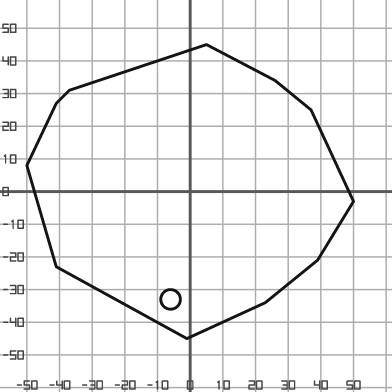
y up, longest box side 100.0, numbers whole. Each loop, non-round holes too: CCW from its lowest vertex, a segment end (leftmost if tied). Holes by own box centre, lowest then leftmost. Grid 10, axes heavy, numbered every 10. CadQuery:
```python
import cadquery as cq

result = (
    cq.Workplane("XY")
    .moveTo(-1.0, -45.0)
    .lineTo(23.0, -34.0)
    .lineTo(39.0, -21.0)
    .lineTo(50.0, -3.0)
    .lineTo(37.0, 25.0)
    .lineTo(26.0, 34.0)
    .lineTo(5.0, 45.0)
    .lineTo(-37.0, 31.0)
    .lineTo(-41.0, 27.0)
    .lineTo(-50.0, 8.0)
    .lineTo(-41.0, -23.0)
    .close()
    .moveTo(-6.0, -33.0)
    .circle(3.0)
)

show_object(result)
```